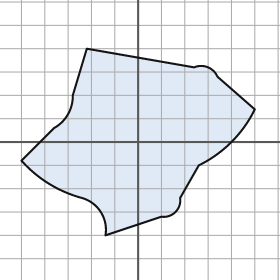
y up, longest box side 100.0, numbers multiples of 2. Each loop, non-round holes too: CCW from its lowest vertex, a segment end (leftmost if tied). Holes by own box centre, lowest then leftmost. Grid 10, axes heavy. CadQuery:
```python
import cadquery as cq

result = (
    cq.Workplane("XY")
    .moveTo(-14.0, -40.0)
    .lineTo(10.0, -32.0)
    .threePointArc((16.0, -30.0), (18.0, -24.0))
    .lineTo(26.0, -10.0)
    .threePointArc((40.0, 0.0), (50.0, 14.0))
    .lineTo(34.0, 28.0)
    .threePointArc((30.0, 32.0), (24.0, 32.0))
    .lineTo(-22.0, 40.0)
    .lineTo(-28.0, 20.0)
    .threePointArc((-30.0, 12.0), (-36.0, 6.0))
    .lineTo(-50.0, -8.0)
    .threePointArc((-38.0, -18.0), (-24.0, -24.0))
    .threePointArc((-16.0, -30.0), (-14.0, -40.0))
    .close()
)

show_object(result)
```